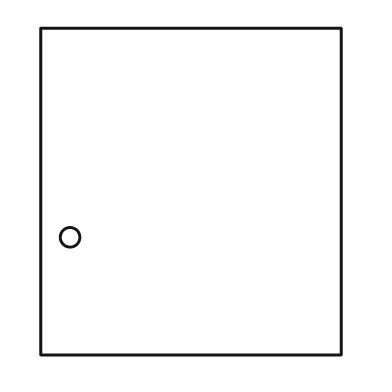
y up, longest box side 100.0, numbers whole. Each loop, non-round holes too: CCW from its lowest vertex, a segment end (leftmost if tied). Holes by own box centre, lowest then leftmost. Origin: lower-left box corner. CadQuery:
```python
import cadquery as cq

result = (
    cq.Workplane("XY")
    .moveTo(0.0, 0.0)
    .lineTo(92.0, 0.0)
    .lineTo(92.0, 100.0)
    .lineTo(0.0, 100.0)
    .close()
    .moveTo(9.0, 36.0)
    .circle(3.0)
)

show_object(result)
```